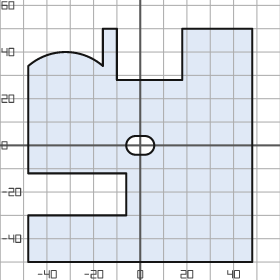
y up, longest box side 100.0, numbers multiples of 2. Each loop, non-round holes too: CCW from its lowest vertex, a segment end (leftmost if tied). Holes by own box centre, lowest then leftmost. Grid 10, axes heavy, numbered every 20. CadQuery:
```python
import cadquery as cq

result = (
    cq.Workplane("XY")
    .moveTo(-48.0, -50.0)
    .lineTo(48.0, -50.0)
    .lineTo(48.0, 50.0)
    .lineTo(18.0, 50.0)
    .lineTo(18.0, 28.0)
    .lineTo(-10.0, 28.0)
    .lineTo(-10.0, 50.0)
    .lineTo(-16.0, 50.0)
    .lineTo(-16.0, 34.0)
    .threePointArc((-32.0, 40.0), (-48.0, 34.0))
    .lineTo(-48.0, -12.0)
    .lineTo(-6.0, -12.0)
    .lineTo(-6.0, -30.0)
    .lineTo(-48.0, -30.0)
    .close()
    .moveTo(-2.0, -4.0)
    .lineTo(2.0, -4.0)
    .threePointArc((6.0, 0.0), (2.0, 4.0))
    .lineTo(-2.0, 4.0)
    .threePointArc((-6.0, 0.0), (-2.0, -4.0))
    .close()
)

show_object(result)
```